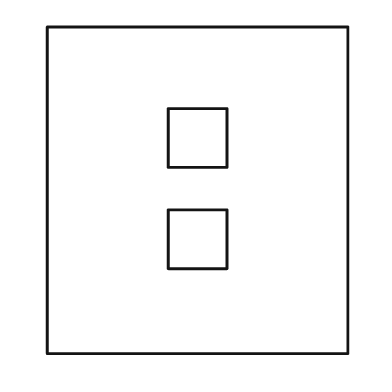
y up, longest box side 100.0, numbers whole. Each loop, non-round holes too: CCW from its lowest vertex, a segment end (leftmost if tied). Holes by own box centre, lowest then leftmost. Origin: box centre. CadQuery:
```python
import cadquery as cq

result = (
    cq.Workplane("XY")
    .moveTo(-46.0, -50.0)
    .lineTo(46.0, -50.0)
    .lineTo(46.0, 50.0)
    .lineTo(-46.0, 50.0)
    .close()
    .moveTo(-9.0, -24.0)
    .lineTo(9.0, -24.0)
    .lineTo(9.0, -6.0)
    .lineTo(-9.0, -6.0)
    .close()
    .moveTo(-9.0, 7.0)
    .lineTo(9.0, 7.0)
    .lineTo(9.0, 25.0)
    .lineTo(-9.0, 25.0)
    .close()
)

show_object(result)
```